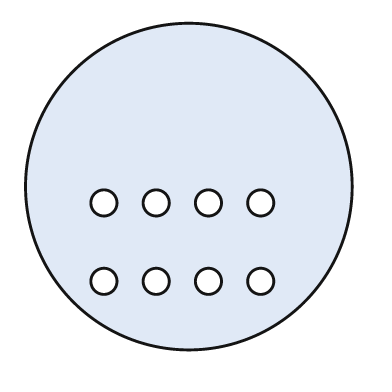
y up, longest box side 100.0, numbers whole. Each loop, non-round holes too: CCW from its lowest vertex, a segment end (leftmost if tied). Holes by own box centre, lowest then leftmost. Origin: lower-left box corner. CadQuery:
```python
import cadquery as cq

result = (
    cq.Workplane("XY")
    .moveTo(50.0, 50.0)
    .circle(50.0)
    .moveTo(24.0, 21.0)
    .circle(4.0)
    .moveTo(40.0, 21.0)
    .circle(4.0)
    .moveTo(56.0, 21.0)
    .circle(4.0)
    .moveTo(72.0, 21.0)
    .circle(4.0)
    .moveTo(24.0, 45.0)
    .circle(4.0)
    .moveTo(40.0, 45.0)
    .circle(4.0)
    .moveTo(56.0, 45.0)
    .circle(4.0)
    .moveTo(72.0, 45.0)
    .circle(4.0)
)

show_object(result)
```